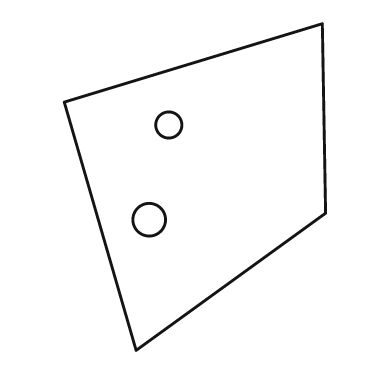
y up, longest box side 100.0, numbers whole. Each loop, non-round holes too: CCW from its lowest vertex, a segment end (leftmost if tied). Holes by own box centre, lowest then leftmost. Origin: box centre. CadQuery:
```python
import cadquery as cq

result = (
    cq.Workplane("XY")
    .moveTo(-18.0, -50.0)
    .lineTo(40.0, -8.0)
    .lineTo(39.0, 50.0)
    .lineTo(-40.0, 26.0)
    .close()
    .moveTo(-14.0, -10.0)
    .circle(5.0)
    .moveTo(-8.0, 19.0)
    .circle(4.0)
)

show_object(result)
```